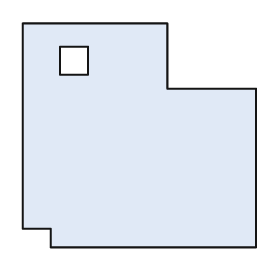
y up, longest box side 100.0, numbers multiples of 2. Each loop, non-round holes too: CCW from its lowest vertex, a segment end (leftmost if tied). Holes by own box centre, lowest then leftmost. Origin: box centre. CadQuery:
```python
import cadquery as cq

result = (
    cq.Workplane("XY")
    .moveTo(-38.0, -48.0)
    .lineTo(50.0, -48.0)
    .lineTo(50.0, 20.0)
    .lineTo(12.0, 20.0)
    .lineTo(12.0, 48.0)
    .lineTo(-50.0, 48.0)
    .lineTo(-50.0, -40.0)
    .lineTo(-38.0, -40.0)
    .close()
    .moveTo(-34.0, 26.0)
    .lineTo(-22.0, 26.0)
    .lineTo(-22.0, 38.0)
    .lineTo(-34.0, 38.0)
    .close()
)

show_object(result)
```